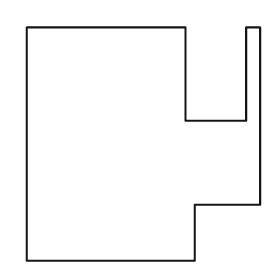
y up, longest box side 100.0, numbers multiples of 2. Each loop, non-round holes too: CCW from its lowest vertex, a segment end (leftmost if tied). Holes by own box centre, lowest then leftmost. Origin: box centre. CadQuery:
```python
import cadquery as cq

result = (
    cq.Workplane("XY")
    .moveTo(-50.0, -50.0)
    .lineTo(22.0, -50.0)
    .lineTo(22.0, -26.0)
    .lineTo(50.0, -26.0)
    .lineTo(50.0, 50.0)
    .lineTo(44.0, 50.0)
    .lineTo(44.0, 10.0)
    .lineTo(18.0, 10.0)
    .lineTo(18.0, 50.0)
    .lineTo(-50.0, 50.0)
    .close()
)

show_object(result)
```